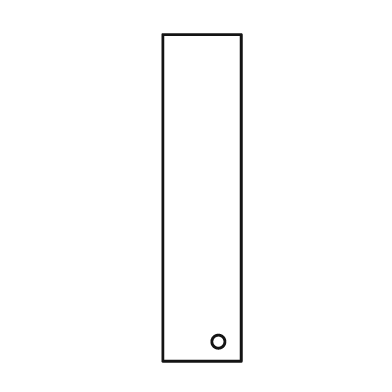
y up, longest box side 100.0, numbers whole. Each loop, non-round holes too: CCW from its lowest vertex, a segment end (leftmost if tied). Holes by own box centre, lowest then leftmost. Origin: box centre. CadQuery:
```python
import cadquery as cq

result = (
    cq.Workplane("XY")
    .moveTo(-12.0, -50.0)
    .lineTo(12.0, -50.0)
    .lineTo(12.0, 50.0)
    .lineTo(-12.0, 50.0)
    .close()
    .moveTo(5.0, -44.0)
    .circle(2.0)
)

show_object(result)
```